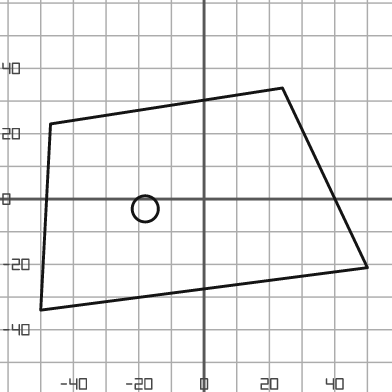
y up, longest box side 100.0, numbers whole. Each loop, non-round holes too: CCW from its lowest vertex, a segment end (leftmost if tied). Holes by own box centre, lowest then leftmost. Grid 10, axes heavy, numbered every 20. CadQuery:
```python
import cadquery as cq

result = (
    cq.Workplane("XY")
    .moveTo(-50.0, -34.0)
    .lineTo(50.0, -21.0)
    .lineTo(24.0, 34.0)
    .lineTo(-47.0, 23.0)
    .close()
    .moveTo(-18.0, -3.0)
    .circle(4.0)
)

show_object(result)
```